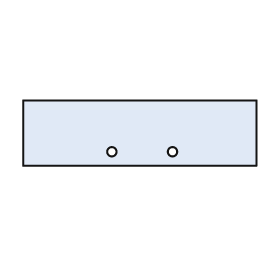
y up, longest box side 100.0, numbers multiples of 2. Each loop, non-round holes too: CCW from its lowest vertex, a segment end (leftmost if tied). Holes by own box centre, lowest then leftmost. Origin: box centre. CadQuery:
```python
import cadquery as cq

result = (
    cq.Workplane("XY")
    .moveTo(-50.0, -14.0)
    .lineTo(50.0, -14.0)
    .lineTo(50.0, 14.0)
    .lineTo(-50.0, 14.0)
    .close()
    .moveTo(-12.0, -8.0)
    .circle(2.0)
    .moveTo(14.0, -8.0)
    .circle(2.0)
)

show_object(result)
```